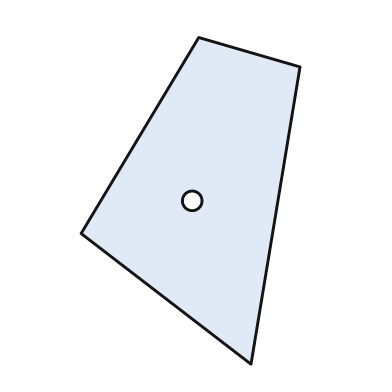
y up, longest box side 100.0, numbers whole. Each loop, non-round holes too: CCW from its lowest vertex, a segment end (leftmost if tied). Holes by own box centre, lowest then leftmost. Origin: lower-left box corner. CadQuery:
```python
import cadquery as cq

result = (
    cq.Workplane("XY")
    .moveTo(52.0, 0.0)
    .lineTo(67.0, 91.0)
    .lineTo(36.0, 100.0)
    .lineTo(0.0, 40.0)
    .close()
    .moveTo(34.0, 50.0)
    .circle(3.0)
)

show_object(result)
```